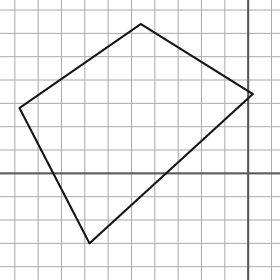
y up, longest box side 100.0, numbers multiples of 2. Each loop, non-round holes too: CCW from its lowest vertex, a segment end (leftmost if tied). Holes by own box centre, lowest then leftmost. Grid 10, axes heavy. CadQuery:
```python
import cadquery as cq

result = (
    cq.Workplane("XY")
    .moveTo(-68.0, -30.0)
    .lineTo(2.0, 34.0)
    .lineTo(-46.0, 64.0)
    .lineTo(-98.0, 28.0)
    .close()
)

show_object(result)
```